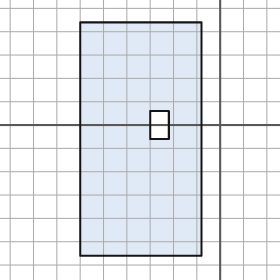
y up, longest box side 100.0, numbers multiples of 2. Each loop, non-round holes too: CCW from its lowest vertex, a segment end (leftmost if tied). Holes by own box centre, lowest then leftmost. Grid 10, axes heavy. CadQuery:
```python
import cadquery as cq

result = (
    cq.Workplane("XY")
    .moveTo(-60.0, -56.0)
    .lineTo(-8.0, -56.0)
    .lineTo(-8.0, 44.0)
    .lineTo(-60.0, 44.0)
    .close()
    .moveTo(-30.0, -6.0)
    .lineTo(-22.0, -6.0)
    .lineTo(-22.0, 6.0)
    .lineTo(-30.0, 6.0)
    .close()
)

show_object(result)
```